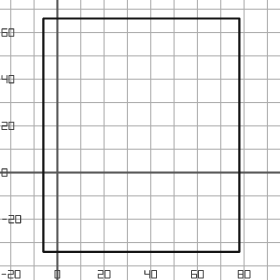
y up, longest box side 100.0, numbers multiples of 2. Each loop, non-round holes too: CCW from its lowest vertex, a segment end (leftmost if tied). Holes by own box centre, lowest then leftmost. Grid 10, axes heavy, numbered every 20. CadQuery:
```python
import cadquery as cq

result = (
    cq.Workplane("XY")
    .moveTo(-6.0, -34.0)
    .lineTo(78.0, -34.0)
    .lineTo(78.0, 66.0)
    .lineTo(-6.0, 66.0)
    .close()
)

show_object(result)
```